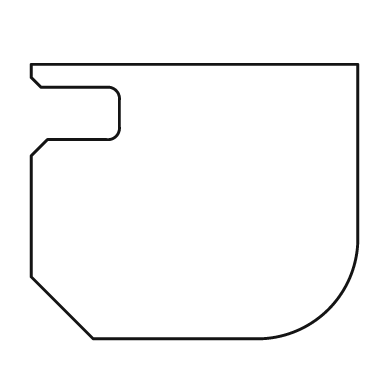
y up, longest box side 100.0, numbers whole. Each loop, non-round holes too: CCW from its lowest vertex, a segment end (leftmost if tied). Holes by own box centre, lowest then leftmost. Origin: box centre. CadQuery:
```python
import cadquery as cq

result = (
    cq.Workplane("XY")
    .moveTo(-31.0, -42.0)
    .lineTo(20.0, -42.0)
    .threePointArc((41.0, -33.0), (50.0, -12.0))
    .lineTo(50.0, 42.0)
    .lineTo(-50.0, 42.0)
    .lineTo(-50.0, 38.0)
    .lineTo(-47.0, 35.0)
    .lineTo(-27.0, 35.0)
    .threePointArc((-24.0, 34.0), (-23.0, 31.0))
    .lineTo(-23.0, 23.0)
    .threePointArc((-24.0, 20.0), (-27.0, 19.0))
    .lineTo(-45.0, 19.0)
    .lineTo(-50.0, 14.0)
    .lineTo(-50.0, -23.0)
    .close()
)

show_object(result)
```